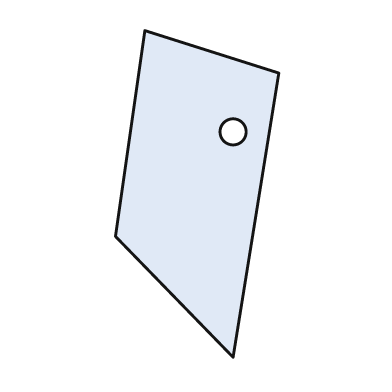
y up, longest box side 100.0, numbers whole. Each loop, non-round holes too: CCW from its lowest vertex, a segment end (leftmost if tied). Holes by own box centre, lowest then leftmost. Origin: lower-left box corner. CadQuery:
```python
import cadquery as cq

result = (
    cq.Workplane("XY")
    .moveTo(36.0, 0.0)
    .lineTo(50.0, 87.0)
    .lineTo(9.0, 100.0)
    .lineTo(0.0, 37.0)
    .close()
    .moveTo(36.0, 69.0)
    .circle(4.0)
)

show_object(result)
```